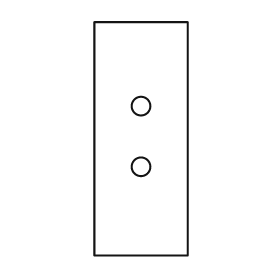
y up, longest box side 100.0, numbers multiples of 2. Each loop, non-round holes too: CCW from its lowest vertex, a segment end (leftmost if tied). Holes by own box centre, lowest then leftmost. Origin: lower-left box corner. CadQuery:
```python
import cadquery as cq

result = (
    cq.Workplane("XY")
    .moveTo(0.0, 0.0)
    .lineTo(40.0, 0.0)
    .lineTo(40.0, 100.0)
    .lineTo(0.0, 100.0)
    .close()
    .moveTo(20.0, 38.0)
    .circle(4.0)
    .moveTo(20.0, 64.0)
    .circle(4.0)
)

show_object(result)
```